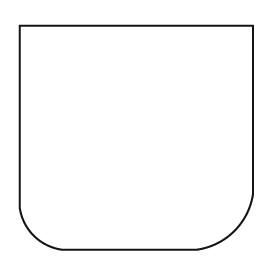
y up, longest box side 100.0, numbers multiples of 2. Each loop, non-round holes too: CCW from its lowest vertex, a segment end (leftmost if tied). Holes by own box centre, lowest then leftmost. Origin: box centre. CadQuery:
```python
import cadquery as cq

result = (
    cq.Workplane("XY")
    .moveTo(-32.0, -48.0)
    .lineTo(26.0, -48.0)
    .threePointArc((42.0, -40.0), (50.0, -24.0))
    .lineTo(50.0, 48.0)
    .lineTo(-50.0, 48.0)
    .lineTo(-50.0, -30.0)
    .threePointArc((-44.0, -42.0), (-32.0, -48.0))
    .close()
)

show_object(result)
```